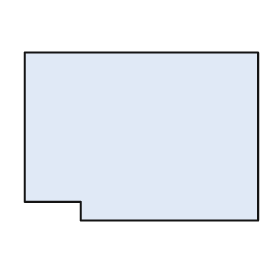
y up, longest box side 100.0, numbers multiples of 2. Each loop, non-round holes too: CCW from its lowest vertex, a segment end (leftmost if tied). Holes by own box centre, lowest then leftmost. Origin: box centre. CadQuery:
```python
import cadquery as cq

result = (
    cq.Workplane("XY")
    .moveTo(-26.0, -36.0)
    .lineTo(50.0, -36.0)
    .lineTo(50.0, 36.0)
    .lineTo(-50.0, 36.0)
    .lineTo(-50.0, -28.0)
    .lineTo(-26.0, -28.0)
    .close()
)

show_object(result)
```